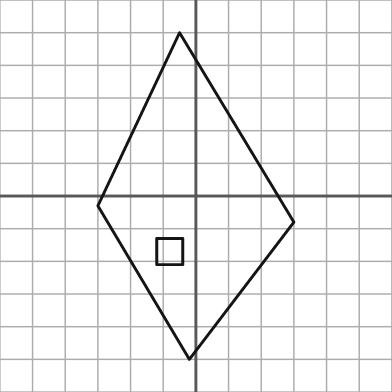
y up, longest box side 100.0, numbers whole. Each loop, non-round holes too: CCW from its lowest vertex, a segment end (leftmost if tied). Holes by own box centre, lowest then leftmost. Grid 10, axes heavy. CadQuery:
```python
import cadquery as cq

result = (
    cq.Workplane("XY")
    .moveTo(-2.0, -50.0)
    .lineTo(30.0, -8.0)
    .lineTo(-5.0, 50.0)
    .lineTo(-30.0, -3.0)
    .close()
    .moveTo(-12.0, -21.0)
    .lineTo(-4.0, -21.0)
    .lineTo(-4.0, -13.0)
    .lineTo(-12.0, -13.0)
    .close()
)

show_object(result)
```